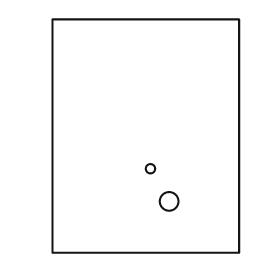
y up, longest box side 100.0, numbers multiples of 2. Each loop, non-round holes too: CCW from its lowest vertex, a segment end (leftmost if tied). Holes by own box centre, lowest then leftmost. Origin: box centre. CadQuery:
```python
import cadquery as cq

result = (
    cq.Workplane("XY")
    .moveTo(-40.0, -50.0)
    .lineTo(40.0, -50.0)
    .lineTo(40.0, 50.0)
    .lineTo(-40.0, 50.0)
    .close()
    .moveTo(10.0, -28.0)
    .circle(4.0)
    .moveTo(2.0, -14.0)
    .circle(2.0)
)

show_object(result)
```